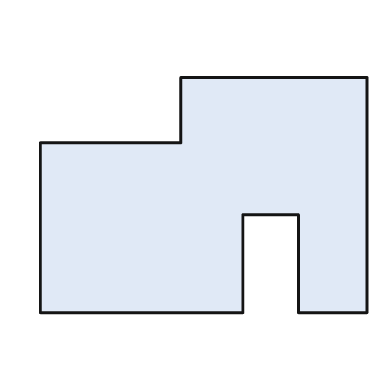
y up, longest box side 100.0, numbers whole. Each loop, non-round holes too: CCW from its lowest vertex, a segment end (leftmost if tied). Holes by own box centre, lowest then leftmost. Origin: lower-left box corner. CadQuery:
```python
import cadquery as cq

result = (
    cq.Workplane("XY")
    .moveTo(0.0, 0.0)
    .lineTo(62.0, 0.0)
    .lineTo(62.0, 30.0)
    .lineTo(79.0, 30.0)
    .lineTo(79.0, 0.0)
    .lineTo(100.0, 0.0)
    .lineTo(100.0, 72.0)
    .lineTo(43.0, 72.0)
    .lineTo(43.0, 52.0)
    .lineTo(0.0, 52.0)
    .close()
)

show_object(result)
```